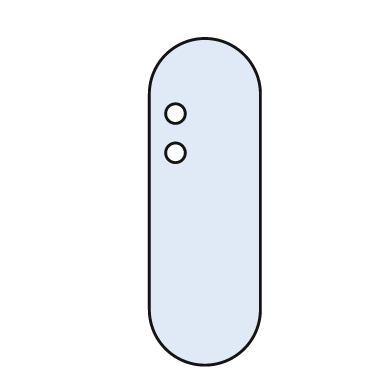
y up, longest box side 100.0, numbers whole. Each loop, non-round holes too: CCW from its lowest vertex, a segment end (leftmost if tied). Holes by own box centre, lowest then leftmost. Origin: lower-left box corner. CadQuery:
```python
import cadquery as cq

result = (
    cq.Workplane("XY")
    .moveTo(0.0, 17.0)
    .threePointArc((17.0, 0.0), (34.0, 17.0))
    .lineTo(34.0, 83.0)
    .threePointArc((17.0, 100.0), (0.0, 83.0))
    .close()
    .moveTo(8.0, 65.0)
    .circle(3.0)
    .moveTo(8.0, 77.0)
    .circle(3.0)
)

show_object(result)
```